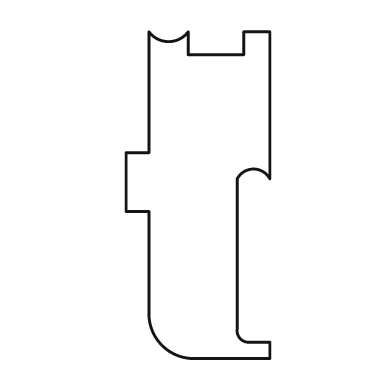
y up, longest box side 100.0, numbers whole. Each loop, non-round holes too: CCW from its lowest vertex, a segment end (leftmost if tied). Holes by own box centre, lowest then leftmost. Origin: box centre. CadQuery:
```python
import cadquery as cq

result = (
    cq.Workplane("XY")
    .moveTo(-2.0, -50.0)
    .lineTo(22.0, -50.0)
    .lineTo(22.0, -45.0)
    .lineTo(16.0, -45.0)
    .threePointArc((13.0, -44.0), (12.0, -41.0))
    .lineTo(12.0, 5.0)
    .threePointArc((17.0, 8.0), (22.0, 5.0))
    .lineTo(22.0, 50.0)
    .lineTo(14.0, 50.0)
    .lineTo(14.0, 43.0)
    .lineTo(-3.0, 43.0)
    .lineTo(-3.0, 50.0)
    .threePointArc((-9.0, 47.0), (-15.0, 50.0))
    .lineTo(-15.0, 13.0)
    .lineTo(-22.0, 13.0)
    .lineTo(-22.0, -5.0)
    .lineTo(-15.0, -5.0)
    .lineTo(-15.0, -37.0)
    .threePointArc((-11.0, -46.0), (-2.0, -50.0))
    .close()
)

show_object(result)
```